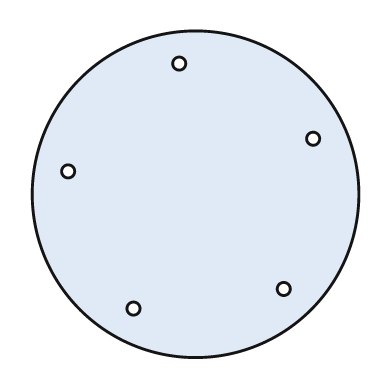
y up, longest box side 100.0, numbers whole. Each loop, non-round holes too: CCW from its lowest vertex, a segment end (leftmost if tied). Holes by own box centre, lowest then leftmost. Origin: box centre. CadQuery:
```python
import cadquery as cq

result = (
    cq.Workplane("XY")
    .moveTo(0.0, 0.0)
    .circle(50.0)
    .moveTo(-19.0, -35.0)
    .circle(2.0)
    .moveTo(27.0, -29.0)
    .circle(2.0)
    .moveTo(-39.0, 7.0)
    .circle(2.0)
    .moveTo(36.0, 17.0)
    .circle(2.0)
    .moveTo(-5.0, 40.0)
    .circle(2.0)
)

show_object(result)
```